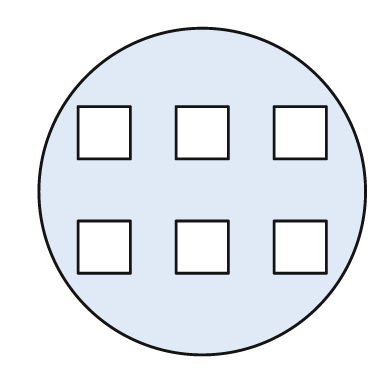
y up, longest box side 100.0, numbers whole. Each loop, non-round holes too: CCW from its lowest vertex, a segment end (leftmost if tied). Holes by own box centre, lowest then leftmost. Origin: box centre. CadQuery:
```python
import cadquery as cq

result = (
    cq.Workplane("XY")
    .moveTo(0.0, 0.0)
    .circle(50.0)
    .moveTo(-38.0, -25.0)
    .lineTo(-22.0, -25.0)
    .lineTo(-22.0, -9.0)
    .lineTo(-38.0, -9.0)
    .close()
    .moveTo(-8.0, -25.0)
    .lineTo(8.0, -25.0)
    .lineTo(8.0, -9.0)
    .lineTo(-8.0, -9.0)
    .close()
    .moveTo(22.0, -25.0)
    .lineTo(38.0, -25.0)
    .lineTo(38.0, -9.0)
    .lineTo(22.0, -9.0)
    .close()
    .moveTo(-38.0, 10.0)
    .lineTo(-22.0, 10.0)
    .lineTo(-22.0, 26.0)
    .lineTo(-38.0, 26.0)
    .close()
    .moveTo(-8.0, 10.0)
    .lineTo(8.0, 10.0)
    .lineTo(8.0, 26.0)
    .lineTo(-8.0, 26.0)
    .close()
    .moveTo(22.0, 10.0)
    .lineTo(38.0, 10.0)
    .lineTo(38.0, 26.0)
    .lineTo(22.0, 26.0)
    .close()
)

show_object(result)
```